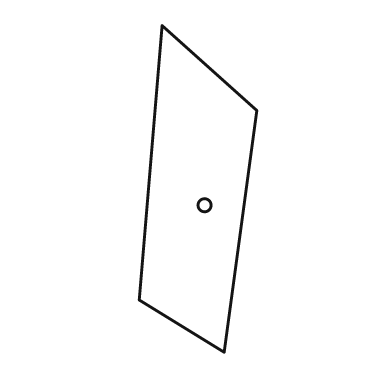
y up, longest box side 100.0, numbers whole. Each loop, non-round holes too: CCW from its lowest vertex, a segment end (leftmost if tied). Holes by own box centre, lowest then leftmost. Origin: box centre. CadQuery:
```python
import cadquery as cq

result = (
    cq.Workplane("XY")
    .moveTo(8.0, -50.0)
    .lineTo(18.0, 24.0)
    .lineTo(-11.0, 50.0)
    .lineTo(-18.0, -34.0)
    .close()
    .moveTo(2.0, -5.0)
    .circle(2.0)
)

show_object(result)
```